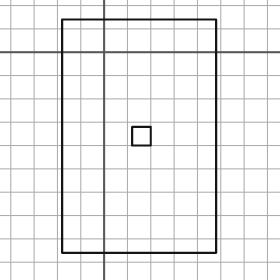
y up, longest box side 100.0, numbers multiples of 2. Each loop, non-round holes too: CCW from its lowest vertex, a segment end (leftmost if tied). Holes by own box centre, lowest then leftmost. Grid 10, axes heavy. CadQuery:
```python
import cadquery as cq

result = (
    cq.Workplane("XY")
    .moveTo(-18.0, -86.0)
    .lineTo(48.0, -86.0)
    .lineTo(48.0, 14.0)
    .lineTo(-18.0, 14.0)
    .close()
    .moveTo(12.0, -40.0)
    .lineTo(20.0, -40.0)
    .lineTo(20.0, -32.0)
    .lineTo(12.0, -32.0)
    .close()
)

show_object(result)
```